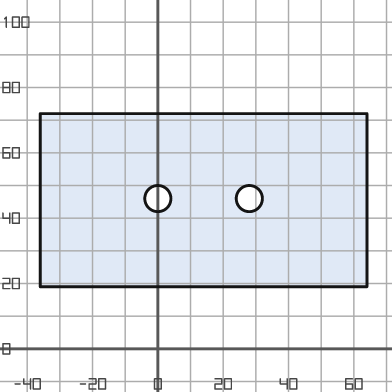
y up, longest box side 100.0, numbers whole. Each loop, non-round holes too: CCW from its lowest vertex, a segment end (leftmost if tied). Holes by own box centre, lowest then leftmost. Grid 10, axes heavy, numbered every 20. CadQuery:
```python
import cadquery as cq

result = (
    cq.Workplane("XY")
    .moveTo(-36.0, 19.0)
    .lineTo(64.0, 19.0)
    .lineTo(64.0, 72.0)
    .lineTo(-36.0, 72.0)
    .close()
    .moveTo(0.0, 46.0)
    .circle(4.0)
    .moveTo(28.0, 46.0)
    .circle(4.0)
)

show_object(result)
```